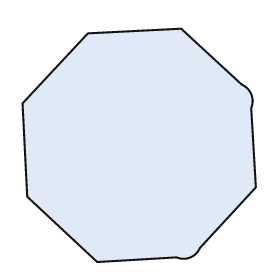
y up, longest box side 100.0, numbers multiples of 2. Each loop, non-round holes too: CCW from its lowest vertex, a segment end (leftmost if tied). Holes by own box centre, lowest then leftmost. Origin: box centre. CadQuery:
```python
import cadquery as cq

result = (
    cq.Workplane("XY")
    .moveTo(-18.0, -50.0)
    .lineTo(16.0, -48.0)
    .threePointArc((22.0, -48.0), (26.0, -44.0))
    .lineTo(50.0, -18.0)
    .lineTo(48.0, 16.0)
    .threePointArc((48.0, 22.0), (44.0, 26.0))
    .lineTo(18.0, 50.0)
    .lineTo(-22.0, 48.0)
    .lineTo(-50.0, 18.0)
    .lineTo(-48.0, -22.0)
    .close()
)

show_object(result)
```